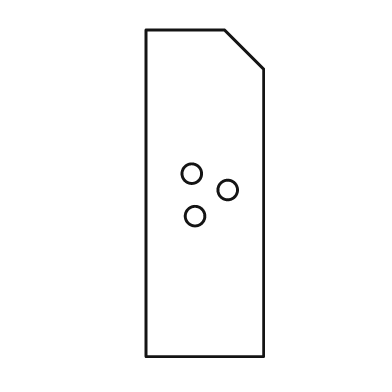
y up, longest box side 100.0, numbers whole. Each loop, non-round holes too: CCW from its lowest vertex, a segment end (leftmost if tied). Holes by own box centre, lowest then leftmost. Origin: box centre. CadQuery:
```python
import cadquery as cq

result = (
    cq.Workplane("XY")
    .moveTo(-18.0, -50.0)
    .lineTo(18.0, -50.0)
    .lineTo(18.0, 38.0)
    .lineTo(6.0, 50.0)
    .lineTo(-18.0, 50.0)
    .close()
    .moveTo(-3.0, -7.0)
    .circle(3.0)
    .moveTo(7.0, 1.0)
    .circle(3.0)
    .moveTo(-4.0, 6.0)
    .circle(3.0)
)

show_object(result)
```